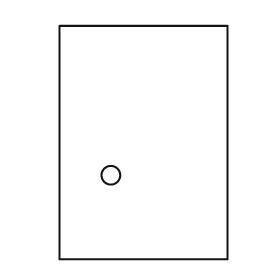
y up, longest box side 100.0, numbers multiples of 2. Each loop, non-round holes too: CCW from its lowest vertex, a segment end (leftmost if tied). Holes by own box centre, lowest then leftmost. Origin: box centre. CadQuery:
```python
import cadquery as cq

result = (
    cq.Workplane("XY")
    .moveTo(-36.0, -50.0)
    .lineTo(36.0, -50.0)
    .lineTo(36.0, 50.0)
    .lineTo(-36.0, 50.0)
    .close()
    .moveTo(-14.0, -14.0)
    .circle(4.0)
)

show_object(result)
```